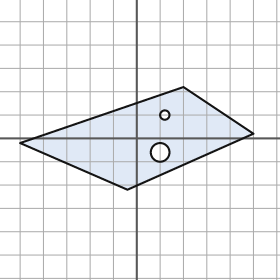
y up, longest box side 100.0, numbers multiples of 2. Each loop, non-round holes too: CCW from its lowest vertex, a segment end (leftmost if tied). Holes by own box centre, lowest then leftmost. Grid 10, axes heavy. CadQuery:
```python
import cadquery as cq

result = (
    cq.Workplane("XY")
    .moveTo(-4.0, -22.0)
    .lineTo(50.0, 2.0)
    .lineTo(20.0, 22.0)
    .lineTo(-50.0, -2.0)
    .close()
    .moveTo(10.0, -6.0)
    .circle(4.0)
    .moveTo(12.0, 10.0)
    .circle(2.0)
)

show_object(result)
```